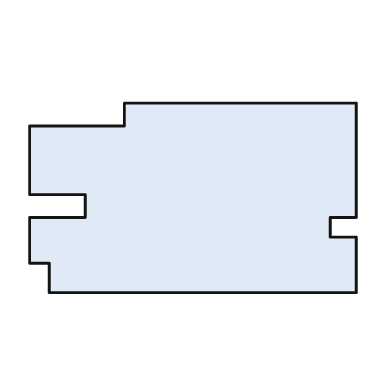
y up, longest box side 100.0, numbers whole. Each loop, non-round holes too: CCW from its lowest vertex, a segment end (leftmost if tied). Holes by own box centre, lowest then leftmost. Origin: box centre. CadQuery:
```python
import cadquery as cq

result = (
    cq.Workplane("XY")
    .moveTo(-44.0, -29.0)
    .lineTo(50.0, -29.0)
    .lineTo(50.0, -12.0)
    .lineTo(42.0, -12.0)
    .lineTo(42.0, -6.0)
    .lineTo(50.0, -6.0)
    .lineTo(50.0, 29.0)
    .lineTo(-21.0, 29.0)
    .lineTo(-21.0, 22.0)
    .lineTo(-50.0, 22.0)
    .lineTo(-50.0, 1.0)
    .lineTo(-33.0, 1.0)
    .lineTo(-33.0, -6.0)
    .lineTo(-50.0, -6.0)
    .lineTo(-50.0, -20.0)
    .lineTo(-44.0, -20.0)
    .close()
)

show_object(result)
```